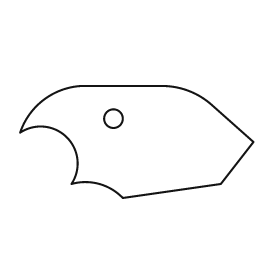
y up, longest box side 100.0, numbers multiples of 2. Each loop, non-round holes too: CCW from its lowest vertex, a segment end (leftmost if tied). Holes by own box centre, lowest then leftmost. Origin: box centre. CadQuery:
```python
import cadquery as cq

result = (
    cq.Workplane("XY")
    .moveTo(-6.0, -24.0)
    .lineTo(36.0, -18.0)
    .lineTo(50.0, 0.0)
    .lineTo(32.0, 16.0)
    .threePointArc((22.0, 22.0), (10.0, 24.0))
    .lineTo(-24.0, 24.0)
    .threePointArc((-40.0, 18.0), (-50.0, 4.0))
    .threePointArc((-30.0, 2.0), (-28.0, -18.0))
    .threePointArc((-16.0, -18.0), (-6.0, -24.0))
    .close()
    .moveTo(-10.0, 10.0)
    .circle(4.0)
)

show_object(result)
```